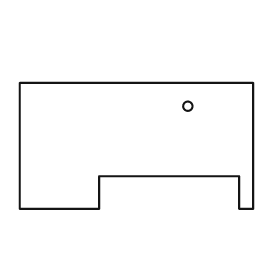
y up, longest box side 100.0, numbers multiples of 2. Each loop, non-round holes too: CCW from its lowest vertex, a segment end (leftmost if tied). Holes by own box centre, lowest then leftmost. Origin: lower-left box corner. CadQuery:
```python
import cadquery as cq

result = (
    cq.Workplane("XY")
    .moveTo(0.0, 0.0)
    .lineTo(34.0, 0.0)
    .lineTo(34.0, 14.0)
    .lineTo(94.0, 14.0)
    .lineTo(94.0, 0.0)
    .lineTo(100.0, 0.0)
    .lineTo(100.0, 54.0)
    .lineTo(0.0, 54.0)
    .close()
    .moveTo(72.0, 44.0)
    .circle(2.0)
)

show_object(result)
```